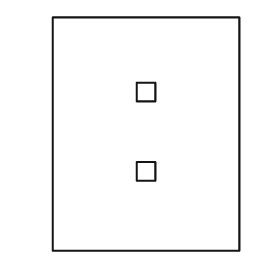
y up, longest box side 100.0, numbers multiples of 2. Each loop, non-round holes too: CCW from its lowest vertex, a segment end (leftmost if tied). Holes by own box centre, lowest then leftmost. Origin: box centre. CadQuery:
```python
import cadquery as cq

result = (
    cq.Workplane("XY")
    .moveTo(-40.0, -50.0)
    .lineTo(40.0, -50.0)
    .lineTo(40.0, 50.0)
    .lineTo(-40.0, 50.0)
    .close()
    .moveTo(-4.0, -20.0)
    .lineTo(4.0, -20.0)
    .lineTo(4.0, -12.0)
    .lineTo(-4.0, -12.0)
    .close()
    .moveTo(-4.0, 14.0)
    .lineTo(4.0, 14.0)
    .lineTo(4.0, 22.0)
    .lineTo(-4.0, 22.0)
    .close()
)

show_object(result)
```